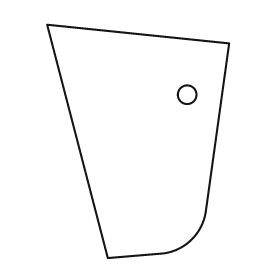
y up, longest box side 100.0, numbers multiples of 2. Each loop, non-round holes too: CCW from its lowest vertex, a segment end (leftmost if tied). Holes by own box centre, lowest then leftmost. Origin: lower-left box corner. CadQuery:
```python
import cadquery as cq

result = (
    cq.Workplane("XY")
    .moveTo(26.0, 0.0)
    .lineTo(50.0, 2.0)
    .threePointArc((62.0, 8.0), (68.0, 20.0))
    .lineTo(78.0, 92.0)
    .lineTo(0.0, 100.0)
    .close()
    .moveTo(60.0, 70.0)
    .circle(4.0)
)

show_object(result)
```